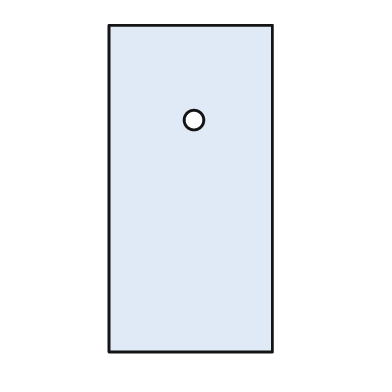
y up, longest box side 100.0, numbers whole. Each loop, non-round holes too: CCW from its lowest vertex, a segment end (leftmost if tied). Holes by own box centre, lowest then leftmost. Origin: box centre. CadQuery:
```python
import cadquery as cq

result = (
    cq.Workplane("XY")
    .moveTo(-25.0, -50.0)
    .lineTo(25.0, -50.0)
    .lineTo(25.0, 50.0)
    .lineTo(-25.0, 50.0)
    .close()
    .moveTo(1.0, 21.0)
    .circle(3.0)
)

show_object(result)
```